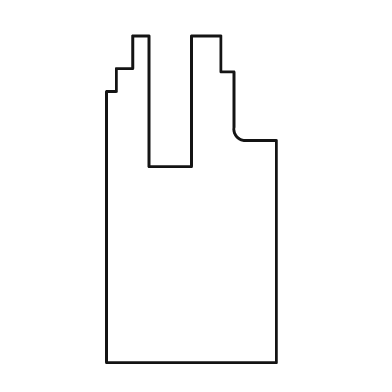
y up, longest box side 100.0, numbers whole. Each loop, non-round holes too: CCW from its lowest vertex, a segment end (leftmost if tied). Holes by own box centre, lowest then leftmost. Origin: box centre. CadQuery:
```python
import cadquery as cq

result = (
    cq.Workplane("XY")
    .moveTo(-26.0, -50.0)
    .lineTo(26.0, -50.0)
    .lineTo(26.0, 18.0)
    .lineTo(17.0, 18.0)
    .threePointArc((14.0, 19.0), (13.0, 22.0))
    .lineTo(13.0, 39.0)
    .lineTo(9.0, 39.0)
    .lineTo(9.0, 50.0)
    .lineTo(0.0, 50.0)
    .lineTo(0.0, 10.0)
    .lineTo(-13.0, 10.0)
    .lineTo(-13.0, 50.0)
    .lineTo(-18.0, 50.0)
    .lineTo(-18.0, 40.0)
    .lineTo(-23.0, 40.0)
    .lineTo(-23.0, 33.0)
    .lineTo(-26.0, 33.0)
    .close()
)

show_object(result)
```